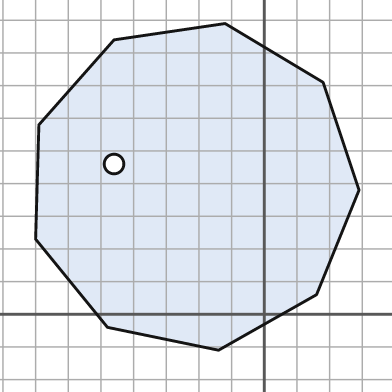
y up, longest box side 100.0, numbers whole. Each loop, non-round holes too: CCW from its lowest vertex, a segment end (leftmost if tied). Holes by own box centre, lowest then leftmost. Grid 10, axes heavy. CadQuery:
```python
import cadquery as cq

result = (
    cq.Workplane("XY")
    .moveTo(-14.0, -11.0)
    .lineTo(16.0, 6.0)
    .lineTo(29.0, 38.0)
    .lineTo(18.0, 71.0)
    .lineTo(-12.0, 89.0)
    .lineTo(-46.0, 84.0)
    .lineTo(-69.0, 58.0)
    .lineTo(-70.0, 23.0)
    .lineTo(-48.0, -4.0)
    .close()
    .moveTo(-46.0, 46.0)
    .circle(3.0)
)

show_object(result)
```